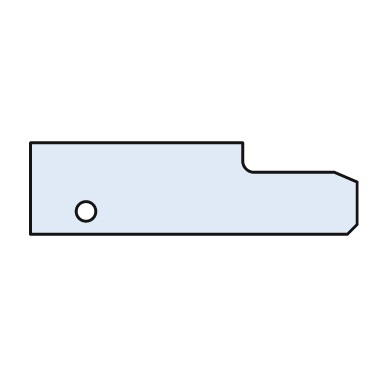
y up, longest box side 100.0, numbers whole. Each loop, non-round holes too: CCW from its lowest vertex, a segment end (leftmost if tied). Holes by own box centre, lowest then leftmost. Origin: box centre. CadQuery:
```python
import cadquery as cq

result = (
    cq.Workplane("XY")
    .moveTo(-50.0, -14.0)
    .lineTo(47.0, -14.0)
    .lineTo(50.0, -11.0)
    .lineTo(50.0, 2.0)
    .lineTo(43.0, 5.0)
    .lineTo(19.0, 5.0)
    .threePointArc((16.0, 6.0), (15.0, 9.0))
    .lineTo(15.0, 14.0)
    .lineTo(-50.0, 14.0)
    .close()
    .moveTo(-33.0, -7.0)
    .circle(3.0)
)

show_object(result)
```